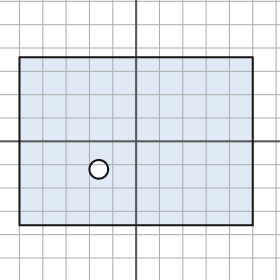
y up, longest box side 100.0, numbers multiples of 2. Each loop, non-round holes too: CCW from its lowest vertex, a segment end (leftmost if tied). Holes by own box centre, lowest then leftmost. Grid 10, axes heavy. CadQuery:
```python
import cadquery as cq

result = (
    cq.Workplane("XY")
    .moveTo(-50.0, -36.0)
    .lineTo(50.0, -36.0)
    .lineTo(50.0, 36.0)
    .lineTo(-50.0, 36.0)
    .close()
    .moveTo(-16.0, -12.0)
    .circle(4.0)
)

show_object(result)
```